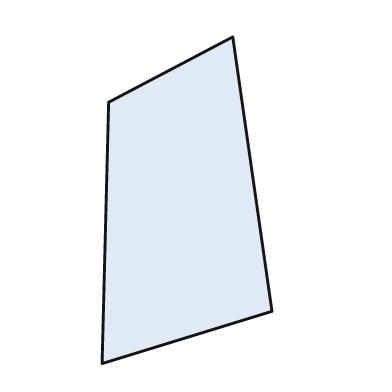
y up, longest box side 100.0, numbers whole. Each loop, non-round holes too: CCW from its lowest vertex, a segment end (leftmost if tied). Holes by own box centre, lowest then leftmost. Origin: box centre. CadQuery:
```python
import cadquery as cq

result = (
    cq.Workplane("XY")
    .moveTo(-26.0, -50.0)
    .lineTo(26.0, -34.0)
    .lineTo(14.0, 50.0)
    .lineTo(-24.0, 30.0)
    .close()
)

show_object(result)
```